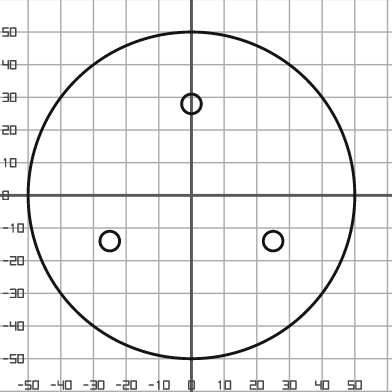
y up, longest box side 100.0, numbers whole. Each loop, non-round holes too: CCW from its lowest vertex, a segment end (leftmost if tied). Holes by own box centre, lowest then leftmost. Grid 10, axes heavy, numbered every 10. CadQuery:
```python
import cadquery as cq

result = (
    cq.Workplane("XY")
    .moveTo(0.0, 0.0)
    .circle(50.0)
    .moveTo(-25.0, -14.0)
    .circle(3.0)
    .moveTo(25.0, -14.0)
    .circle(3.0)
    .moveTo(0.0, 28.0)
    .circle(3.0)
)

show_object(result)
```